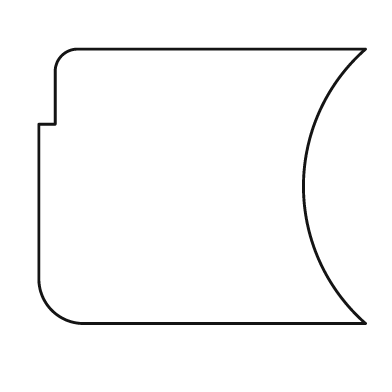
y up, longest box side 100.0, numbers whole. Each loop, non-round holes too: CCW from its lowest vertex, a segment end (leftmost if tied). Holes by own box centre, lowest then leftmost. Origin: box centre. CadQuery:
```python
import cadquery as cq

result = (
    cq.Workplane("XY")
    .moveTo(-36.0, -42.0)
    .lineTo(50.0, -42.0)
    .threePointArc((31.0, 0.0), (50.0, 42.0))
    .lineTo(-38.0, 42.0)
    .threePointArc((-43.0, 40.0), (-45.0, 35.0))
    .lineTo(-45.0, 19.0)
    .lineTo(-50.0, 19.0)
    .lineTo(-50.0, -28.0)
    .threePointArc((-46.0, -38.0), (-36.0, -42.0))
    .close()
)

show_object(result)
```